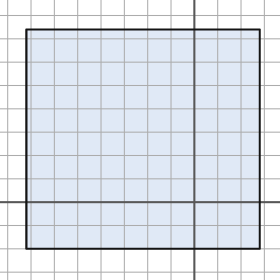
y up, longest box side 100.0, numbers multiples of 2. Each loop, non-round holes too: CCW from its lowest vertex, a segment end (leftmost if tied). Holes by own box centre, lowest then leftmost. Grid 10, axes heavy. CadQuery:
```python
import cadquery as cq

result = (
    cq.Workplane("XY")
    .moveTo(-72.0, -20.0)
    .lineTo(28.0, -20.0)
    .lineTo(28.0, 74.0)
    .lineTo(-72.0, 74.0)
    .close()
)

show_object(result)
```